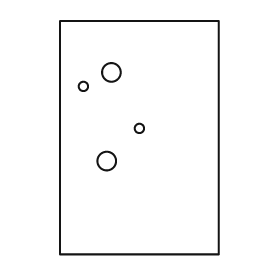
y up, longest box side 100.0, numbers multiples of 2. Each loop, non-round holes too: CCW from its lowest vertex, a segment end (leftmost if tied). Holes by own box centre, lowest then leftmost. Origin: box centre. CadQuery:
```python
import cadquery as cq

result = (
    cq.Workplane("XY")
    .moveTo(-34.0, -50.0)
    .lineTo(34.0, -50.0)
    .lineTo(34.0, 50.0)
    .lineTo(-34.0, 50.0)
    .close()
    .moveTo(-14.0, -10.0)
    .circle(4.0)
    .moveTo(0.0, 4.0)
    .circle(2.0)
    .moveTo(-24.0, 22.0)
    .circle(2.0)
    .moveTo(-12.0, 28.0)
    .circle(4.0)
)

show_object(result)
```